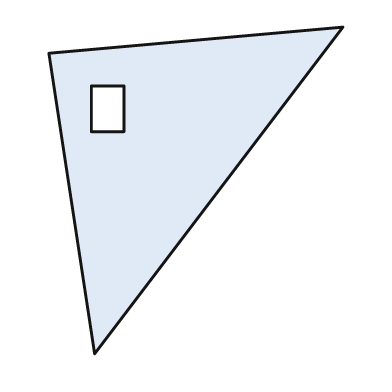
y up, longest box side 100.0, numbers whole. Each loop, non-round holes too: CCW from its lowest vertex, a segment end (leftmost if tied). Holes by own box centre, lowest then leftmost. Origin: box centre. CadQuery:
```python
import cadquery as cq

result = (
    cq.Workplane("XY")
    .moveTo(-31.0, -50.0)
    .lineTo(45.0, 50.0)
    .lineTo(-45.0, 42.0)
    .close()
    .moveTo(-32.0, 18.0)
    .lineTo(-22.0, 18.0)
    .lineTo(-22.0, 32.0)
    .lineTo(-32.0, 32.0)
    .close()
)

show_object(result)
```